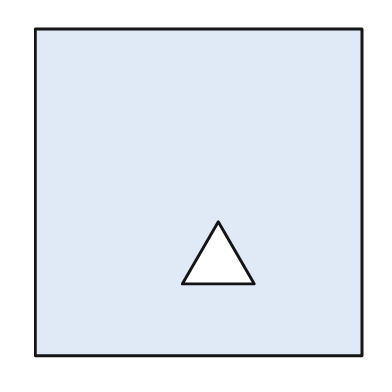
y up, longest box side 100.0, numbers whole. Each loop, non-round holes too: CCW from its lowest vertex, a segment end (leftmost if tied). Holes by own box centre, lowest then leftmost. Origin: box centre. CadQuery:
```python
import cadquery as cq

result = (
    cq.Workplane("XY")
    .moveTo(-50.0, -50.0)
    .lineTo(50.0, -50.0)
    .lineTo(50.0, 50.0)
    .lineTo(-50.0, 50.0)
    .close()
    .moveTo(-5.0, -28.0)
    .lineTo(17.0, -28.0)
    .lineTo(6.0, -9.0)
    .close()
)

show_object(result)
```